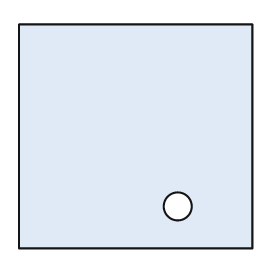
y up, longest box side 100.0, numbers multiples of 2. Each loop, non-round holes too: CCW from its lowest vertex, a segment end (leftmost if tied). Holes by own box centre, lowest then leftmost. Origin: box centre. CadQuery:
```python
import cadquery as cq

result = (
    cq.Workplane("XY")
    .moveTo(-50.0, -48.0)
    .lineTo(50.0, -48.0)
    .lineTo(50.0, 48.0)
    .lineTo(-50.0, 48.0)
    .close()
    .moveTo(18.0, -30.0)
    .circle(6.0)
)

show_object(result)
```